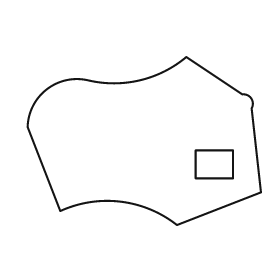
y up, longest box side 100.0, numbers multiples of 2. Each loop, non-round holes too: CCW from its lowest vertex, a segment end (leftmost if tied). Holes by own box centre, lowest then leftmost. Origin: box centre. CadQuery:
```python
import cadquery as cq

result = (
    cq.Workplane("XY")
    .moveTo(14.0, -36.0)
    .lineTo(50.0, -22.0)
    .lineTo(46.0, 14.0)
    .threePointArc((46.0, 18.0), (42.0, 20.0))
    .lineTo(18.0, 36.0)
    .threePointArc((-2.0, 26.0), (-24.0, 26.0))
    .threePointArc((-42.0, 22.0), (-50.0, 6.0))
    .lineTo(-36.0, -30.0)
    .threePointArc((-10.0, -26.0), (14.0, -36.0))
    .close()
    .moveTo(22.0, -16.0)
    .lineTo(38.0, -16.0)
    .lineTo(38.0, -4.0)
    .lineTo(22.0, -4.0)
    .close()
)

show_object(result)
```